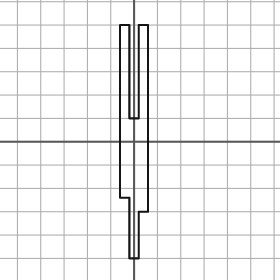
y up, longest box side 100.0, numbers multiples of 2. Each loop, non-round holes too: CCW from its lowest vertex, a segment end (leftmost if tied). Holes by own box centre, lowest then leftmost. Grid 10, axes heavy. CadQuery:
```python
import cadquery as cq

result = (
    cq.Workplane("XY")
    .moveTo(-2.0, -50.0)
    .lineTo(2.0, -50.0)
    .lineTo(2.0, -30.0)
    .lineTo(6.0, -30.0)
    .lineTo(6.0, 50.0)
    .lineTo(2.0, 50.0)
    .lineTo(2.0, 10.0)
    .lineTo(-2.0, 10.0)
    .lineTo(-2.0, 50.0)
    .lineTo(-6.0, 50.0)
    .lineTo(-6.0, -24.0)
    .lineTo(-2.0, -24.0)
    .close()
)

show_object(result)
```